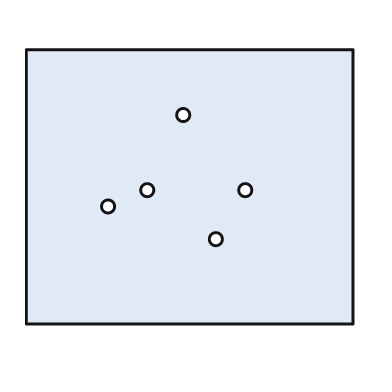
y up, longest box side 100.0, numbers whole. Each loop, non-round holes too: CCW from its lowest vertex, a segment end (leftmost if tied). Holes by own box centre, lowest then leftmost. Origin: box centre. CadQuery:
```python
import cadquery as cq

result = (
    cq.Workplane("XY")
    .moveTo(-50.0, -42.0)
    .lineTo(50.0, -42.0)
    .lineTo(50.0, 42.0)
    .lineTo(-50.0, 42.0)
    .close()
    .moveTo(8.0, -16.0)
    .circle(2.0)
    .moveTo(-25.0, -6.0)
    .circle(2.0)
    .moveTo(-13.0, -1.0)
    .circle(2.0)
    .moveTo(17.0, -1.0)
    .circle(2.0)
    .moveTo(-2.0, 22.0)
    .circle(2.0)
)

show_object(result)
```